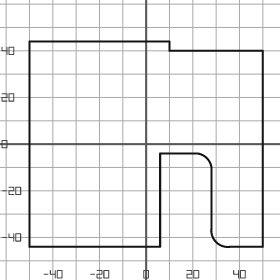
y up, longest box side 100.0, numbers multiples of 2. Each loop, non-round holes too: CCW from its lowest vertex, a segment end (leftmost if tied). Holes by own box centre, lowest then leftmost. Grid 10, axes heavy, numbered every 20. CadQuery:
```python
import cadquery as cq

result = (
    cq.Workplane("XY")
    .moveTo(-50.0, -44.0)
    .lineTo(6.0, -44.0)
    .lineTo(6.0, -4.0)
    .lineTo(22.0, -4.0)
    .threePointArc((26.0, -6.0), (28.0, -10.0))
    .lineTo(28.0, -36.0)
    .threePointArc((30.0, -42.0), (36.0, -44.0))
    .lineTo(50.0, -44.0)
    .lineTo(50.0, 40.0)
    .lineTo(10.0, 40.0)
    .lineTo(10.0, 44.0)
    .lineTo(-50.0, 44.0)
    .close()
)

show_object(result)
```